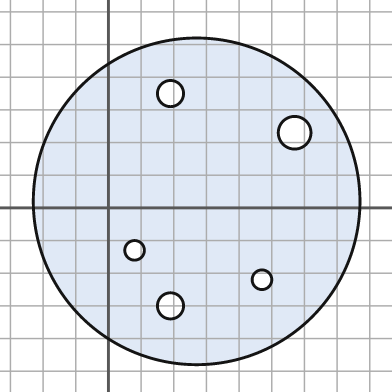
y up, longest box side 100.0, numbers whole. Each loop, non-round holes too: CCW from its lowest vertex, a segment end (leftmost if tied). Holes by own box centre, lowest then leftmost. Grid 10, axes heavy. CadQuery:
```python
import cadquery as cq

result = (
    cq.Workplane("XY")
    .moveTo(27.0, 2.0)
    .circle(50.0)
    .moveTo(19.0, -30.0)
    .circle(4.0)
    .moveTo(47.0, -22.0)
    .circle(3.0)
    .moveTo(8.0, -13.0)
    .circle(3.0)
    .moveTo(57.0, 23.0)
    .circle(5.0)
    .moveTo(19.0, 35.0)
    .circle(4.0)
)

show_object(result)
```